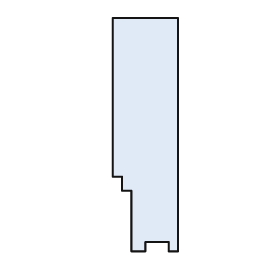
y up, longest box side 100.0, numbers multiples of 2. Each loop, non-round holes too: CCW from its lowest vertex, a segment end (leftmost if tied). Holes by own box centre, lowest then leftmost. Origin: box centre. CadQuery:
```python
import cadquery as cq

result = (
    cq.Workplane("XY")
    .moveTo(-6.0, -50.0)
    .lineTo(0.0, -50.0)
    .lineTo(0.0, -46.0)
    .lineTo(10.0, -46.0)
    .lineTo(10.0, -50.0)
    .lineTo(14.0, -50.0)
    .lineTo(14.0, 50.0)
    .lineTo(-14.0, 50.0)
    .lineTo(-14.0, -18.0)
    .lineTo(-10.0, -18.0)
    .lineTo(-10.0, -24.0)
    .lineTo(-6.0, -24.0)
    .close()
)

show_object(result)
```